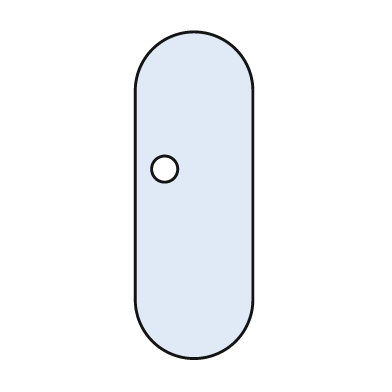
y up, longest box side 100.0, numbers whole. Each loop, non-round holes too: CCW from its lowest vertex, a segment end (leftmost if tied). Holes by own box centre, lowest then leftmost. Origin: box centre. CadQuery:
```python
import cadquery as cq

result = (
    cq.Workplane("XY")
    .moveTo(-18.0, -32.0)
    .threePointArc((0.0, -50.0), (18.0, -32.0))
    .lineTo(18.0, 32.0)
    .threePointArc((0.0, 50.0), (-18.0, 32.0))
    .close()
    .moveTo(-9.0, 8.0)
    .circle(4.0)
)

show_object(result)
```